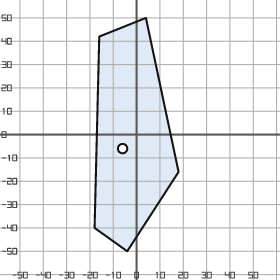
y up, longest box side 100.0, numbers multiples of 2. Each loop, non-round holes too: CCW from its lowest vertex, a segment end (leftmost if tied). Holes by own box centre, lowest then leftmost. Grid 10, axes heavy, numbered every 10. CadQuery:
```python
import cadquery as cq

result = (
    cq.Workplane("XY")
    .moveTo(-4.0, -50.0)
    .lineTo(18.0, -16.0)
    .lineTo(4.0, 50.0)
    .lineTo(-16.0, 42.0)
    .lineTo(-18.0, -40.0)
    .close()
    .moveTo(-6.0, -6.0)
    .circle(2.0)
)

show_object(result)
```